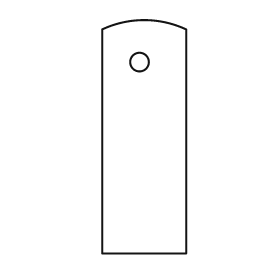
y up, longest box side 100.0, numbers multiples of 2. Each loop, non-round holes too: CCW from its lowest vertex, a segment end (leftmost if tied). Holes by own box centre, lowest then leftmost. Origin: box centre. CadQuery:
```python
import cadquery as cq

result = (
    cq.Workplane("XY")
    .moveTo(-18.0, -50.0)
    .lineTo(18.0, -50.0)
    .lineTo(18.0, 46.0)
    .threePointArc((0.0, 50.0), (-18.0, 46.0))
    .close()
    .moveTo(-2.0, 32.0)
    .circle(4.0)
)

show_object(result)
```